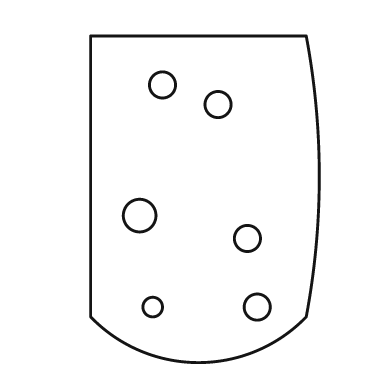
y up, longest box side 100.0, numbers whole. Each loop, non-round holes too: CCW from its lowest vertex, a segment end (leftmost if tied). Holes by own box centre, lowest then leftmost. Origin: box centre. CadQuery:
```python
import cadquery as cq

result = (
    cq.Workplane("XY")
    .moveTo(-35.0, -36.0)
    .threePointArc((-2.0, -50.0), (31.0, -36.0))
    .threePointArc((35.0, 7.0), (31.0, 50.0))
    .lineTo(-35.0, 50.0)
    .close()
    .moveTo(-16.0, -33.0)
    .circle(3.0)
    .moveTo(16.0, -33.0)
    .circle(4.0)
    .moveTo(13.0, -12.0)
    .circle(4.0)
    .moveTo(-20.0, -5.0)
    .circle(5.0)
    .moveTo(4.0, 29.0)
    .circle(4.0)
    .moveTo(-13.0, 35.0)
    .circle(4.0)
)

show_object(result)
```